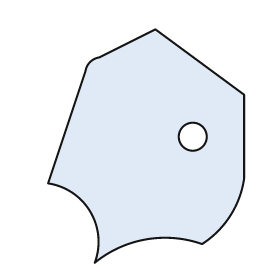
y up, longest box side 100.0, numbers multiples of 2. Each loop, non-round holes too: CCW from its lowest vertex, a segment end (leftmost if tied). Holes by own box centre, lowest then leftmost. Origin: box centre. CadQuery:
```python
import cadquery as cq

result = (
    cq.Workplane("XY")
    .moveTo(-22.0, -50.0)
    .threePointArc((0.0, -40.0), (24.0, -42.0))
    .threePointArc((36.0, -30.0), (42.0, -14.0))
    .lineTo(42.0, 22.0)
    .lineTo(4.0, 50.0)
    .lineTo(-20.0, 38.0)
    .threePointArc((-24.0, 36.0), (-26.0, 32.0))
    .lineTo(-42.0, -16.0)
    .threePointArc((-24.0, -28.0), (-22.0, -50.0))
    .close()
    .moveTo(20.0, 4.0)
    .circle(6.0)
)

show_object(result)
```